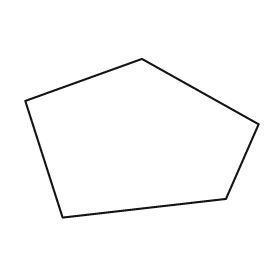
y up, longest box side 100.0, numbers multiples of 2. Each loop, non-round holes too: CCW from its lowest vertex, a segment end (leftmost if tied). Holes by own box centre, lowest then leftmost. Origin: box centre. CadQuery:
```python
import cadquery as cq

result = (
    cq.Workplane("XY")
    .moveTo(-34.0, -34.0)
    .lineTo(36.0, -26.0)
    .lineTo(50.0, 6.0)
    .lineTo(0.0, 34.0)
    .lineTo(-50.0, 16.0)
    .close()
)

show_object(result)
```